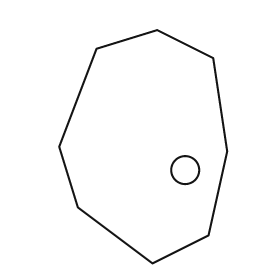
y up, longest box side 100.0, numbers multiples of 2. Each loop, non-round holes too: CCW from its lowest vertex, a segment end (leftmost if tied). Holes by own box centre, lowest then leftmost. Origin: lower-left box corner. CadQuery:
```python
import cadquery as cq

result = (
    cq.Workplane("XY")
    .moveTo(40.0, 0.0)
    .lineTo(64.0, 12.0)
    .lineTo(72.0, 48.0)
    .lineTo(66.0, 88.0)
    .lineTo(42.0, 100.0)
    .lineTo(16.0, 92.0)
    .lineTo(0.0, 50.0)
    .lineTo(8.0, 24.0)
    .close()
    .moveTo(54.0, 40.0)
    .circle(6.0)
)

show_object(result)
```